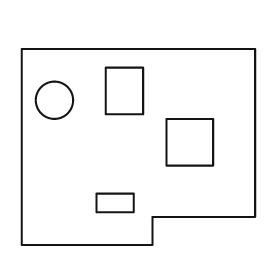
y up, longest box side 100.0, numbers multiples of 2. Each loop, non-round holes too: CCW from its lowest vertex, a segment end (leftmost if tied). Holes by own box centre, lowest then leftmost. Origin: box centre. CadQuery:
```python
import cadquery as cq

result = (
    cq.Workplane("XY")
    .moveTo(-50.0, -42.0)
    .lineTo(6.0, -42.0)
    .lineTo(6.0, -30.0)
    .lineTo(50.0, -30.0)
    .lineTo(50.0, 42.0)
    .lineTo(-50.0, 42.0)
    .close()
    .moveTo(-18.0, -28.0)
    .lineTo(-2.0, -28.0)
    .lineTo(-2.0, -20.0)
    .lineTo(-18.0, -20.0)
    .close()
    .moveTo(12.0, -8.0)
    .lineTo(32.0, -8.0)
    .lineTo(32.0, 12.0)
    .lineTo(12.0, 12.0)
    .close()
    .moveTo(-36.0, 20.0)
    .circle(8.0)
    .moveTo(-14.0, 14.0)
    .lineTo(2.0, 14.0)
    .lineTo(2.0, 34.0)
    .lineTo(-14.0, 34.0)
    .close()
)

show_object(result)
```